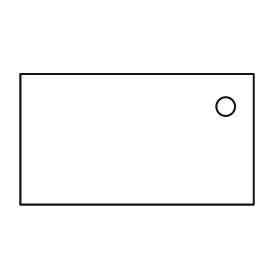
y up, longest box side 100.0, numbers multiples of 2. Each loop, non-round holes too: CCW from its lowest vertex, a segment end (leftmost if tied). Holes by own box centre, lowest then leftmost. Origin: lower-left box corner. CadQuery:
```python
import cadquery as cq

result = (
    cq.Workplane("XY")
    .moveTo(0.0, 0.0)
    .lineTo(100.0, 0.0)
    .lineTo(100.0, 56.0)
    .lineTo(0.0, 56.0)
    .close()
    .moveTo(88.0, 42.0)
    .circle(4.0)
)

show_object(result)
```